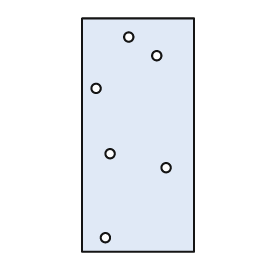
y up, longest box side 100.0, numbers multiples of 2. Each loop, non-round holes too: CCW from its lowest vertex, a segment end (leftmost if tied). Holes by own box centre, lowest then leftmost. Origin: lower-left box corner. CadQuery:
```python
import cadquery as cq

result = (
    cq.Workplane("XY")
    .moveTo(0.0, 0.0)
    .lineTo(48.0, 0.0)
    .lineTo(48.0, 100.0)
    .lineTo(0.0, 100.0)
    .close()
    .moveTo(10.0, 6.0)
    .circle(2.0)
    .moveTo(36.0, 36.0)
    .circle(2.0)
    .moveTo(12.0, 42.0)
    .circle(2.0)
    .moveTo(6.0, 70.0)
    .circle(2.0)
    .moveTo(32.0, 84.0)
    .circle(2.0)
    .moveTo(20.0, 92.0)
    .circle(2.0)
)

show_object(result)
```